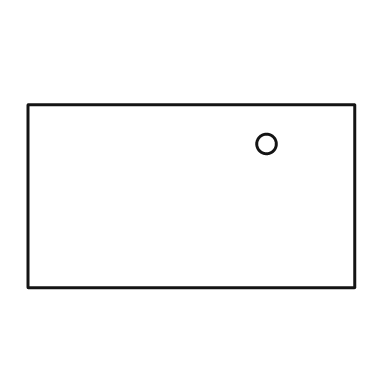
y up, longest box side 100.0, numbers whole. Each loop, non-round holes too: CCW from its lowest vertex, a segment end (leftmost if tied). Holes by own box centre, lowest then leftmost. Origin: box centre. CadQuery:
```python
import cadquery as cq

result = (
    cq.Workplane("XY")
    .moveTo(-50.0, -28.0)
    .lineTo(50.0, -28.0)
    .lineTo(50.0, 28.0)
    .lineTo(-50.0, 28.0)
    .close()
    .moveTo(23.0, 16.0)
    .circle(3.0)
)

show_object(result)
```